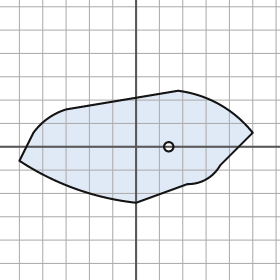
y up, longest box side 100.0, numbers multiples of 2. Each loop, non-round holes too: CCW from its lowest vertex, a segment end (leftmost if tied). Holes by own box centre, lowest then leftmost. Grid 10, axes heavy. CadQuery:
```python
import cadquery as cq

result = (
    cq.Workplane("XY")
    .moveTo(0.0, -24.0)
    .lineTo(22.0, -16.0)
    .threePointArc((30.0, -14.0), (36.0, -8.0))
    .lineTo(50.0, 6.0)
    .threePointArc((36.0, 18.0), (18.0, 24.0))
    .lineTo(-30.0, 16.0)
    .threePointArc((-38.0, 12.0), (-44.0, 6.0))
    .lineTo(-50.0, -6.0)
    .threePointArc((-26.0, -18.0), (0.0, -24.0))
    .close()
    .moveTo(14.0, 0.0)
    .circle(2.0)
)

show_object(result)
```